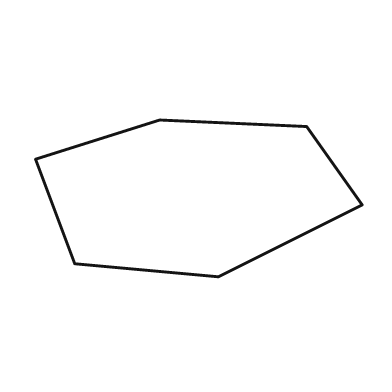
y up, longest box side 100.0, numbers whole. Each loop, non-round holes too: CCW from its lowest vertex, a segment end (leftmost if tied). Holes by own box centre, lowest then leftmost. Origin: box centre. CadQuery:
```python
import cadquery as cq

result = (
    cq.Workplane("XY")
    .moveTo(6.0, -24.0)
    .lineTo(50.0, -2.0)
    .lineTo(33.0, 22.0)
    .lineTo(-12.0, 24.0)
    .lineTo(-50.0, 12.0)
    .lineTo(-38.0, -20.0)
    .close()
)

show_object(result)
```